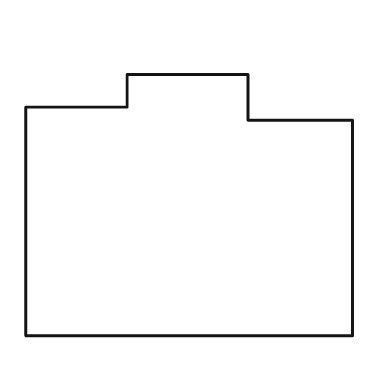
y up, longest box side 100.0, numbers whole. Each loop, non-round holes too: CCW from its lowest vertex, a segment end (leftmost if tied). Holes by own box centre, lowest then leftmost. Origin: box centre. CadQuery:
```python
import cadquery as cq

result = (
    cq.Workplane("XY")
    .moveTo(-50.0, -40.0)
    .lineTo(50.0, -40.0)
    .lineTo(50.0, 26.0)
    .lineTo(18.0, 26.0)
    .lineTo(18.0, 40.0)
    .lineTo(-19.0, 40.0)
    .lineTo(-19.0, 30.0)
    .lineTo(-50.0, 30.0)
    .close()
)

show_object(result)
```